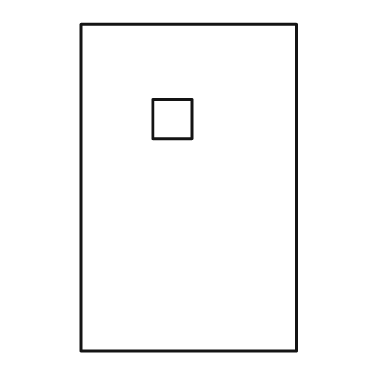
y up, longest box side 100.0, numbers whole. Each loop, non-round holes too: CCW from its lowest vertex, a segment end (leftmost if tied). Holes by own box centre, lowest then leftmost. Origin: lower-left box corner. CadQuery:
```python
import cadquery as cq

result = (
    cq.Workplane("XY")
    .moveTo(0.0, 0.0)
    .lineTo(66.0, 0.0)
    .lineTo(66.0, 100.0)
    .lineTo(0.0, 100.0)
    .close()
    .moveTo(22.0, 65.0)
    .lineTo(34.0, 65.0)
    .lineTo(34.0, 77.0)
    .lineTo(22.0, 77.0)
    .close()
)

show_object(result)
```